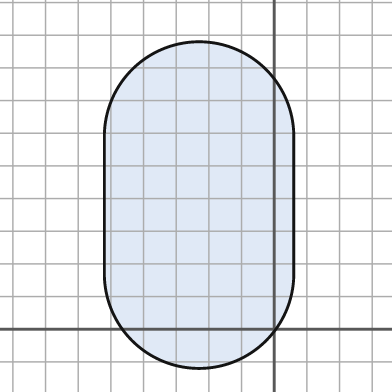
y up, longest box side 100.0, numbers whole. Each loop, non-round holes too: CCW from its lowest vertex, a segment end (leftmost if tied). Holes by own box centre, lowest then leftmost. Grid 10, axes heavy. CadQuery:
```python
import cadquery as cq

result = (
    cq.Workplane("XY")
    .moveTo(-52.0, 17.0)
    .threePointArc((-23.0, -12.0), (6.0, 17.0))
    .lineTo(6.0, 59.0)
    .threePointArc((-23.0, 88.0), (-52.0, 59.0))
    .close()
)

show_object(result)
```